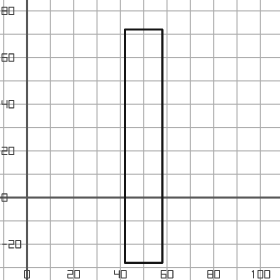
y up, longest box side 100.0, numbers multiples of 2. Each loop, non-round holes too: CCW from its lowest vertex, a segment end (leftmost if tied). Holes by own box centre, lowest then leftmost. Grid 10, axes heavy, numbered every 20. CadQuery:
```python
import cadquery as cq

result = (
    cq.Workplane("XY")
    .moveTo(42.0, -28.0)
    .lineTo(58.0, -28.0)
    .lineTo(58.0, 72.0)
    .lineTo(42.0, 72.0)
    .close()
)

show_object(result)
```